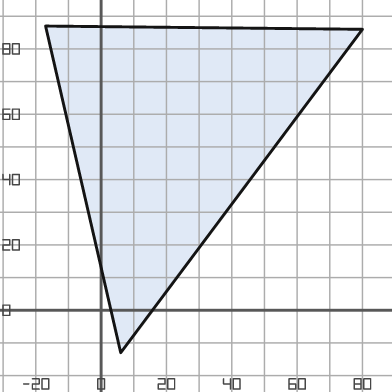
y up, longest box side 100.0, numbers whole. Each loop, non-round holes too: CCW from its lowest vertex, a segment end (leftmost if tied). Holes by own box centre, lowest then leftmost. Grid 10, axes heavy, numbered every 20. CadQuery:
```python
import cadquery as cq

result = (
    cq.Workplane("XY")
    .moveTo(6.0, -13.0)
    .lineTo(80.0, 86.0)
    .lineTo(-17.0, 87.0)
    .close()
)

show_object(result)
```